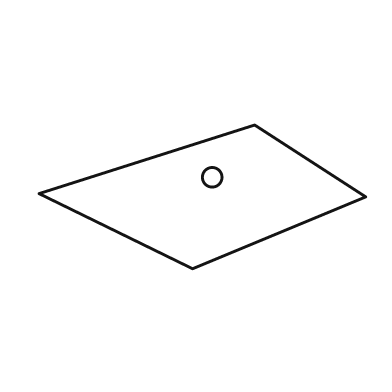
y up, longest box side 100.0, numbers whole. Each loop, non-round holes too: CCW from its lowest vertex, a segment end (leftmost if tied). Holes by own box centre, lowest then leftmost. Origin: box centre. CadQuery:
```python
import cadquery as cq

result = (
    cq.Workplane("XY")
    .moveTo(-3.0, -22.0)
    .lineTo(50.0, 0.0)
    .lineTo(16.0, 22.0)
    .lineTo(-50.0, 1.0)
    .close()
    .moveTo(3.0, 6.0)
    .circle(3.0)
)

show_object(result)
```